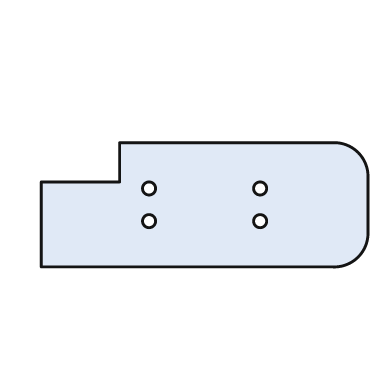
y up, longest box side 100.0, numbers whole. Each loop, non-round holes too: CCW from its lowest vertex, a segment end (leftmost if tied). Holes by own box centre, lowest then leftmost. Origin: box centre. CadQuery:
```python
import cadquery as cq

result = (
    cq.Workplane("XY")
    .moveTo(-50.0, -19.0)
    .lineTo(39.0, -19.0)
    .threePointArc((47.0, -16.0), (50.0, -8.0))
    .lineTo(50.0, 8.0)
    .threePointArc((47.0, 16.0), (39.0, 19.0))
    .lineTo(-26.0, 19.0)
    .lineTo(-26.0, 7.0)
    .lineTo(-50.0, 7.0)
    .close()
    .moveTo(-17.0, -5.0)
    .circle(2.0)
    .moveTo(17.0, -5.0)
    .circle(2.0)
    .moveTo(-17.0, 5.0)
    .circle(2.0)
    .moveTo(17.0, 5.0)
    .circle(2.0)
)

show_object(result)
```